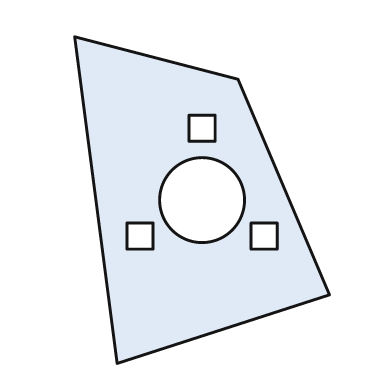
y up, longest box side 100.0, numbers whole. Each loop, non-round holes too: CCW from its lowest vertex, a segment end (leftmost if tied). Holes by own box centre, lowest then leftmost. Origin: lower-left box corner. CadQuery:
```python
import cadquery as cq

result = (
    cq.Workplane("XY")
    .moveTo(13.0, 0.0)
    .lineTo(78.0, 21.0)
    .lineTo(50.0, 87.0)
    .lineTo(0.0, 100.0)
    .close()
    .moveTo(16.0, 35.0)
    .lineTo(24.0, 35.0)
    .lineTo(24.0, 43.0)
    .lineTo(16.0, 43.0)
    .close()
    .moveTo(54.0, 35.0)
    .lineTo(62.0, 35.0)
    .lineTo(62.0, 43.0)
    .lineTo(54.0, 43.0)
    .close()
    .moveTo(39.0, 50.0)
    .circle(13.0)
    .moveTo(35.0, 68.0)
    .lineTo(43.0, 68.0)
    .lineTo(43.0, 76.0)
    .lineTo(35.0, 76.0)
    .close()
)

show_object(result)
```